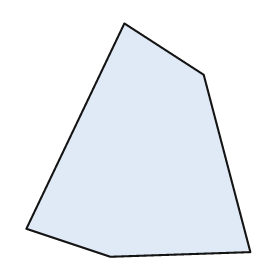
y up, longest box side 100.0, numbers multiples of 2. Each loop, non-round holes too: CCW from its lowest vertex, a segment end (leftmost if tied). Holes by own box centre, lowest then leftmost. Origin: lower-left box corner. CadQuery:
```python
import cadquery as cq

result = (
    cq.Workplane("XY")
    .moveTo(36.0, 0.0)
    .lineTo(96.0, 2.0)
    .lineTo(76.0, 78.0)
    .lineTo(42.0, 100.0)
    .lineTo(0.0, 12.0)
    .close()
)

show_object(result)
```